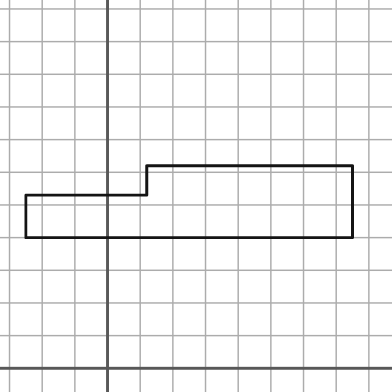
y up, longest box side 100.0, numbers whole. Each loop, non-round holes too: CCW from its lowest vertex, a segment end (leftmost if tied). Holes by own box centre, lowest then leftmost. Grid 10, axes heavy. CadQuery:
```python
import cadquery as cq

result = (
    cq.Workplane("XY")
    .moveTo(-25.0, 40.0)
    .lineTo(75.0, 40.0)
    .lineTo(75.0, 62.0)
    .lineTo(12.0, 62.0)
    .lineTo(12.0, 53.0)
    .lineTo(-25.0, 53.0)
    .close()
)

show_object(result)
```